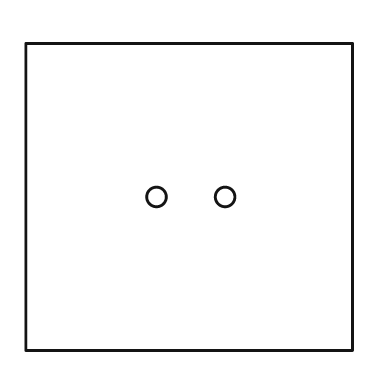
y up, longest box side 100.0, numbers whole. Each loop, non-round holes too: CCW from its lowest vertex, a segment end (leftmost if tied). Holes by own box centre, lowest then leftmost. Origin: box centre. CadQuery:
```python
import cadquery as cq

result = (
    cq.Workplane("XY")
    .moveTo(-50.0, -47.0)
    .lineTo(50.0, -47.0)
    .lineTo(50.0, 47.0)
    .lineTo(-50.0, 47.0)
    .close()
    .moveTo(-10.0, 0.0)
    .circle(3.0)
    .moveTo(11.0, 0.0)
    .circle(3.0)
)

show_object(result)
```